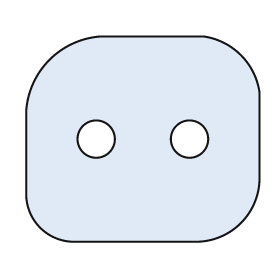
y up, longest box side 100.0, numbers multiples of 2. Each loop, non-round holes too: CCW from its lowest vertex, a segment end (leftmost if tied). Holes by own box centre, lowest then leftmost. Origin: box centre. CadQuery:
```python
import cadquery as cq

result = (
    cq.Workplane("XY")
    .moveTo(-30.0, -44.0)
    .lineTo(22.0, -44.0)
    .threePointArc((42.0, -36.0), (50.0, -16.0))
    .lineTo(50.0, 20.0)
    .threePointArc((42.0, 36.0), (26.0, 44.0))
    .lineTo(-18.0, 44.0)
    .threePointArc((-40.0, 34.0), (-50.0, 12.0))
    .lineTo(-50.0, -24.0)
    .threePointArc((-44.0, -38.0), (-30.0, -44.0))
    .close()
    .moveTo(-20.0, 0.0)
    .circle(8.0)
    .moveTo(20.0, 0.0)
    .circle(8.0)
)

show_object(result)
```